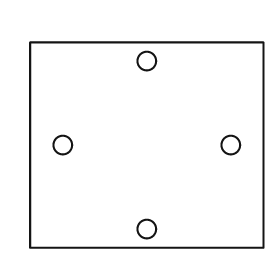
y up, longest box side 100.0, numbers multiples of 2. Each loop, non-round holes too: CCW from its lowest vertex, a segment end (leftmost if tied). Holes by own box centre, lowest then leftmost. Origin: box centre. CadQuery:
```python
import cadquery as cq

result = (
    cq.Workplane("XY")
    .moveTo(-50.0, -44.0)
    .lineTo(50.0, -44.0)
    .lineTo(50.0, 44.0)
    .lineTo(-50.0, 44.0)
    .close()
    .moveTo(0.0, -36.0)
    .circle(4.0)
    .moveTo(-36.0, 0.0)
    .circle(4.0)
    .moveTo(36.0, 0.0)
    .circle(4.0)
    .moveTo(0.0, 36.0)
    .circle(4.0)
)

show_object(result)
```